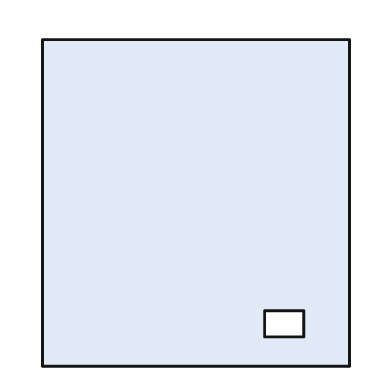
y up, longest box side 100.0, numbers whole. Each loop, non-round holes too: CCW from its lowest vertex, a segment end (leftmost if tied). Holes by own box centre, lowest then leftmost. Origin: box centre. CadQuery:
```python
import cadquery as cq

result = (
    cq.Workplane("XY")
    .moveTo(-47.0, -50.0)
    .lineTo(47.0, -50.0)
    .lineTo(47.0, 50.0)
    .lineTo(-47.0, 50.0)
    .close()
    .moveTo(21.0, -41.0)
    .lineTo(33.0, -41.0)
    .lineTo(33.0, -33.0)
    .lineTo(21.0, -33.0)
    .close()
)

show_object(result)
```